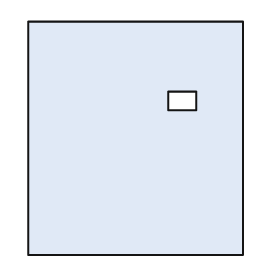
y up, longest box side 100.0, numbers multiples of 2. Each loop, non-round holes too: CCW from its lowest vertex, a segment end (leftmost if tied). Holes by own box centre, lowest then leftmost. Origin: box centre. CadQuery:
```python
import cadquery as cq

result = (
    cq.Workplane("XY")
    .moveTo(-46.0, -50.0)
    .lineTo(46.0, -50.0)
    .lineTo(46.0, 50.0)
    .lineTo(-46.0, 50.0)
    .close()
    .moveTo(14.0, 12.0)
    .lineTo(26.0, 12.0)
    .lineTo(26.0, 20.0)
    .lineTo(14.0, 20.0)
    .close()
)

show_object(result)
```